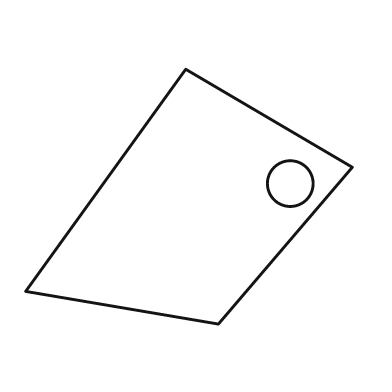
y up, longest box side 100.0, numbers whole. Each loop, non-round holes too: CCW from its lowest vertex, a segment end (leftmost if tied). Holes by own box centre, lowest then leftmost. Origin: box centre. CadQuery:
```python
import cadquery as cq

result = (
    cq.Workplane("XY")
    .moveTo(9.0, -39.0)
    .lineTo(50.0, 9.0)
    .lineTo(-1.0, 39.0)
    .lineTo(-50.0, -29.0)
    .close()
    .moveTo(31.0, 4.0)
    .circle(7.0)
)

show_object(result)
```